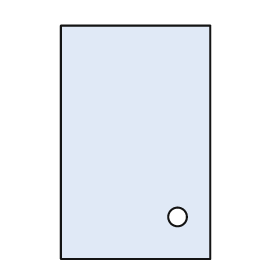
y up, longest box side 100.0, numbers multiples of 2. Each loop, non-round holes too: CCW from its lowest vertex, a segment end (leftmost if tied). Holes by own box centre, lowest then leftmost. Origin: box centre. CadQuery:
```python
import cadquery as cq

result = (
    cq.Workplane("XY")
    .moveTo(-32.0, -50.0)
    .lineTo(32.0, -50.0)
    .lineTo(32.0, 50.0)
    .lineTo(-32.0, 50.0)
    .close()
    .moveTo(18.0, -32.0)
    .circle(4.0)
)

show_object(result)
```